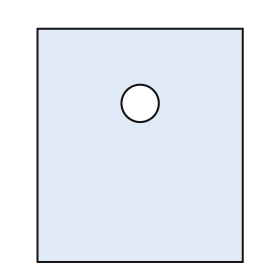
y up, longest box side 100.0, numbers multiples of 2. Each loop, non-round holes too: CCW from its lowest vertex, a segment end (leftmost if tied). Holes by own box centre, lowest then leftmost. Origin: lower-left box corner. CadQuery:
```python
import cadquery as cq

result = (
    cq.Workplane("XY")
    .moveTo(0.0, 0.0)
    .lineTo(88.0, 0.0)
    .lineTo(88.0, 100.0)
    .lineTo(0.0, 100.0)
    .close()
    .moveTo(44.0, 68.0)
    .circle(8.0)
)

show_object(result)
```